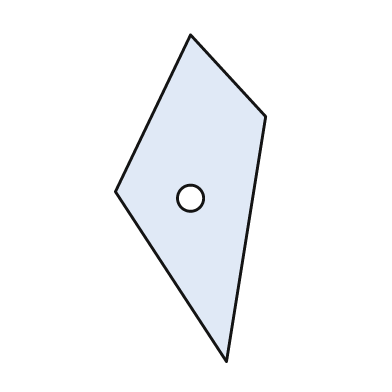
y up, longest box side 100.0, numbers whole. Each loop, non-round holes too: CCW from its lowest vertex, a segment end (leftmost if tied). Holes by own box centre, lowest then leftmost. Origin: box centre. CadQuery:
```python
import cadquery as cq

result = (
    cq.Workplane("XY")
    .moveTo(11.0, -50.0)
    .lineTo(23.0, 25.0)
    .lineTo(0.0, 50.0)
    .lineTo(-23.0, 2.0)
    .close()
    .moveTo(0.0, 0.0)
    .circle(4.0)
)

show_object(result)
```